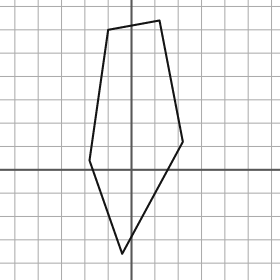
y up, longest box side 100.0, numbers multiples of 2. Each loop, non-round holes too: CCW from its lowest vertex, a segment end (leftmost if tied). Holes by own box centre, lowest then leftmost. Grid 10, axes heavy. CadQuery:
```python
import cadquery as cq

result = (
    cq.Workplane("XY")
    .moveTo(-4.0, -36.0)
    .lineTo(22.0, 12.0)
    .lineTo(12.0, 64.0)
    .lineTo(-10.0, 60.0)
    .lineTo(-18.0, 4.0)
    .close()
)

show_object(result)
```